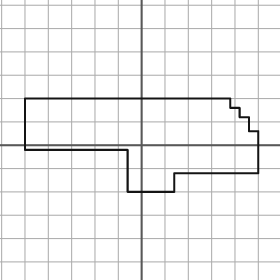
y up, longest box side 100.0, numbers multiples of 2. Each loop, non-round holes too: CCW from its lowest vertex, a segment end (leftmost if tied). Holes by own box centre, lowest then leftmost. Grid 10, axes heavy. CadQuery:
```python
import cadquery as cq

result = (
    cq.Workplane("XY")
    .moveTo(-6.0, -20.0)
    .lineTo(14.0, -20.0)
    .lineTo(14.0, -12.0)
    .lineTo(50.0, -12.0)
    .lineTo(50.0, 6.0)
    .lineTo(46.0, 6.0)
    .lineTo(46.0, 12.0)
    .lineTo(42.0, 12.0)
    .lineTo(42.0, 16.0)
    .lineTo(38.0, 16.0)
    .lineTo(38.0, 20.0)
    .lineTo(-50.0, 20.0)
    .lineTo(-50.0, -2.0)
    .lineTo(-6.0, -2.0)
    .close()
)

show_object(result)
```